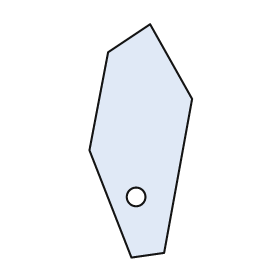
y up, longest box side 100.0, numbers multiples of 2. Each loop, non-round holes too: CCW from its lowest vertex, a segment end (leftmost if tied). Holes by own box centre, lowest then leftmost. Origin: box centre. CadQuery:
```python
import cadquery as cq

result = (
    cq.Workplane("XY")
    .moveTo(-4.0, -50.0)
    .lineTo(10.0, -48.0)
    .lineTo(22.0, 18.0)
    .lineTo(4.0, 50.0)
    .lineTo(-14.0, 38.0)
    .lineTo(-22.0, -4.0)
    .close()
    .moveTo(-2.0, -24.0)
    .circle(4.0)
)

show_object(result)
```